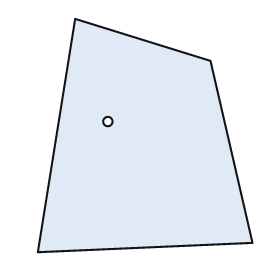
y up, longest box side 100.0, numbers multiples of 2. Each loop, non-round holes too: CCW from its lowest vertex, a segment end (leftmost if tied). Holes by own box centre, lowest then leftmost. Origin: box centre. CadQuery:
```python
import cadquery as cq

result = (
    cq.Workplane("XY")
    .moveTo(-46.0, -50.0)
    .lineTo(46.0, -46.0)
    .lineTo(28.0, 32.0)
    .lineTo(-30.0, 50.0)
    .close()
    .moveTo(-16.0, 6.0)
    .circle(2.0)
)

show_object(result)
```